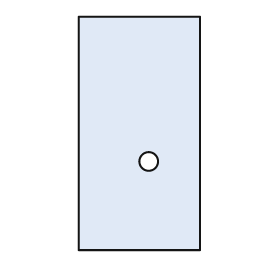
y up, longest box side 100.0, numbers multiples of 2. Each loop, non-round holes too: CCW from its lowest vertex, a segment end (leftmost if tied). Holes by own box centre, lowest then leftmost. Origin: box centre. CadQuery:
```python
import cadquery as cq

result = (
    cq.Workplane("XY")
    .moveTo(-26.0, -50.0)
    .lineTo(26.0, -50.0)
    .lineTo(26.0, 50.0)
    .lineTo(-26.0, 50.0)
    .close()
    .moveTo(4.0, -12.0)
    .circle(4.0)
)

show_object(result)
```